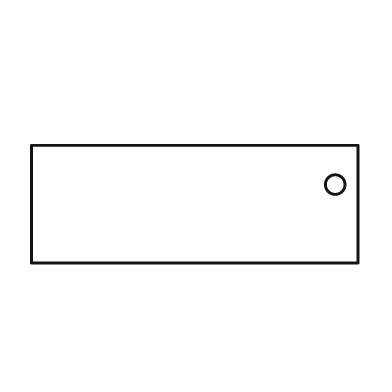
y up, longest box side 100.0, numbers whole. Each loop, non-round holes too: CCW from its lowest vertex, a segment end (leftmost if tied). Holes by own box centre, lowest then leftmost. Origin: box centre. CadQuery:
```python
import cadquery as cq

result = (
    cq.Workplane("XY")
    .moveTo(-50.0, -18.0)
    .lineTo(50.0, -18.0)
    .lineTo(50.0, 18.0)
    .lineTo(-50.0, 18.0)
    .close()
    .moveTo(43.0, 6.0)
    .circle(3.0)
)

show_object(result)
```